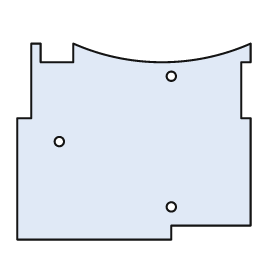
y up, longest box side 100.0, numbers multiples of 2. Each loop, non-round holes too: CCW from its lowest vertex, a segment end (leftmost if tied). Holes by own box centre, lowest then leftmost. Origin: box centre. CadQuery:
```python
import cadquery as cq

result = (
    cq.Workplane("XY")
    .moveTo(-50.0, -42.0)
    .lineTo(16.0, -42.0)
    .lineTo(16.0, -36.0)
    .lineTo(50.0, -36.0)
    .lineTo(50.0, 10.0)
    .lineTo(46.0, 10.0)
    .lineTo(46.0, 34.0)
    .lineTo(50.0, 34.0)
    .lineTo(50.0, 42.0)
    .threePointArc((12.0, 34.0), (-26.0, 42.0))
    .lineTo(-26.0, 34.0)
    .lineTo(-40.0, 34.0)
    .lineTo(-40.0, 42.0)
    .lineTo(-44.0, 42.0)
    .lineTo(-44.0, 10.0)
    .lineTo(-50.0, 10.0)
    .close()
    .moveTo(16.0, -28.0)
    .circle(2.0)
    .moveTo(-32.0, 0.0)
    .circle(2.0)
    .moveTo(16.0, 28.0)
    .circle(2.0)
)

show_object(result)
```